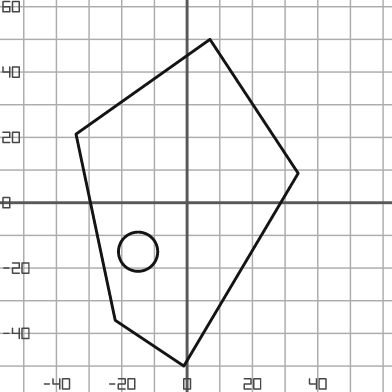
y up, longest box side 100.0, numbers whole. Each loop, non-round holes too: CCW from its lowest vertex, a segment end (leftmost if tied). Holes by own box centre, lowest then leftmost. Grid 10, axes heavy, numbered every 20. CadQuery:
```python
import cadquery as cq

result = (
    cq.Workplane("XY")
    .moveTo(-1.0, -50.0)
    .lineTo(34.0, 9.0)
    .lineTo(7.0, 50.0)
    .lineTo(-34.0, 21.0)
    .lineTo(-22.0, -36.0)
    .close()
    .moveTo(-15.0, -15.0)
    .circle(6.0)
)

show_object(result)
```